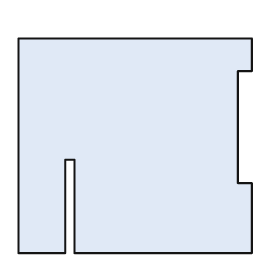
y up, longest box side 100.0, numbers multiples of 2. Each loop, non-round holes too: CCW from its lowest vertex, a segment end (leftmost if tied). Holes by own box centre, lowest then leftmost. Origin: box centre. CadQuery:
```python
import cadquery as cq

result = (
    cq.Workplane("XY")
    .moveTo(-50.0, -46.0)
    .lineTo(-30.0, -46.0)
    .lineTo(-30.0, -6.0)
    .lineTo(-26.0, -6.0)
    .lineTo(-26.0, -46.0)
    .lineTo(50.0, -46.0)
    .lineTo(50.0, -16.0)
    .lineTo(44.0, -16.0)
    .lineTo(44.0, 32.0)
    .lineTo(50.0, 32.0)
    .lineTo(50.0, 46.0)
    .lineTo(-50.0, 46.0)
    .close()
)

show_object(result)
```